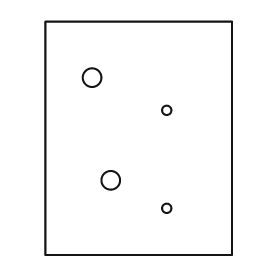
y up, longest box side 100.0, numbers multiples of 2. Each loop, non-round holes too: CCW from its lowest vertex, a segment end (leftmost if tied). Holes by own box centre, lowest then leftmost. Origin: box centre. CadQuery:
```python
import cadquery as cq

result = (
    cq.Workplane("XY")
    .moveTo(-40.0, -50.0)
    .lineTo(40.0, -50.0)
    .lineTo(40.0, 50.0)
    .lineTo(-40.0, 50.0)
    .close()
    .moveTo(12.0, -30.0)
    .circle(2.0)
    .moveTo(-12.0, -18.0)
    .circle(4.0)
    .moveTo(12.0, 12.0)
    .circle(2.0)
    .moveTo(-20.0, 26.0)
    .circle(4.0)
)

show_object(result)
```